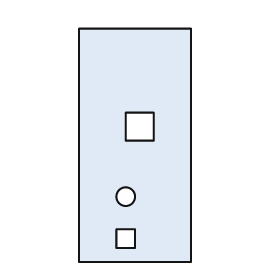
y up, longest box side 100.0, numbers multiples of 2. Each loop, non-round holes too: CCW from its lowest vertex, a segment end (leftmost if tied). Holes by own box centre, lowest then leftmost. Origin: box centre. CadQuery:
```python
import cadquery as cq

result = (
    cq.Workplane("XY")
    .moveTo(-24.0, -50.0)
    .lineTo(24.0, -50.0)
    .lineTo(24.0, 50.0)
    .lineTo(-24.0, 50.0)
    .close()
    .moveTo(-8.0, -44.0)
    .lineTo(0.0, -44.0)
    .lineTo(0.0, -36.0)
    .lineTo(-8.0, -36.0)
    .close()
    .moveTo(-4.0, -22.0)
    .circle(4.0)
    .moveTo(-4.0, 2.0)
    .lineTo(8.0, 2.0)
    .lineTo(8.0, 14.0)
    .lineTo(-4.0, 14.0)
    .close()
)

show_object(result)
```